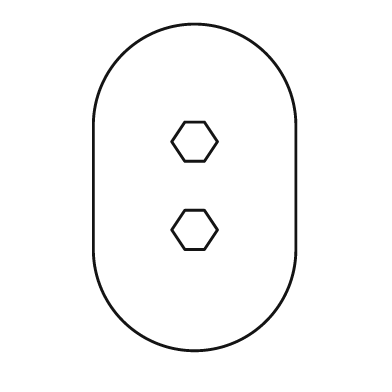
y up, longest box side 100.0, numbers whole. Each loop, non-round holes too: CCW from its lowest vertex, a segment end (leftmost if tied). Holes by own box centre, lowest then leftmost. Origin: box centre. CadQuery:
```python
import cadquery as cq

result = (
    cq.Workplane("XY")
    .moveTo(-31.0, -19.0)
    .threePointArc((0.0, -50.0), (31.0, -19.0))
    .lineTo(31.0, 19.0)
    .threePointArc((0.0, 50.0), (-31.0, 19.0))
    .close()
    .moveTo(-3.0, -19.0)
    .lineTo(3.0, -19.0)
    .lineTo(7.0, -13.0)
    .lineTo(3.0, -7.0)
    .lineTo(-3.0, -7.0)
    .lineTo(-7.0, -13.0)
    .close()
    .moveTo(-3.0, 8.0)
    .lineTo(3.0, 8.0)
    .lineTo(7.0, 14.0)
    .lineTo(3.0, 20.0)
    .lineTo(-3.0, 20.0)
    .lineTo(-7.0, 14.0)
    .close()
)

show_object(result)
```